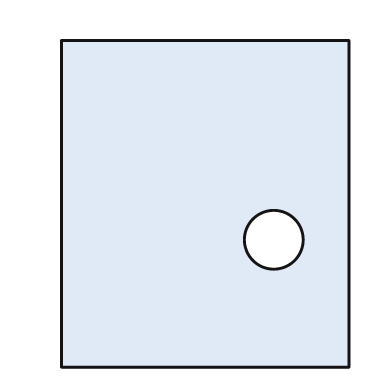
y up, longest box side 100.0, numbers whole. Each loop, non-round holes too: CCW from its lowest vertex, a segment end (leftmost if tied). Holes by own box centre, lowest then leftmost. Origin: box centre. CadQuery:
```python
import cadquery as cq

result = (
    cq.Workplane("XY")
    .moveTo(-44.0, -50.0)
    .lineTo(44.0, -50.0)
    .lineTo(44.0, 50.0)
    .lineTo(-44.0, 50.0)
    .close()
    .moveTo(21.0, -11.0)
    .circle(9.0)
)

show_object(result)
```